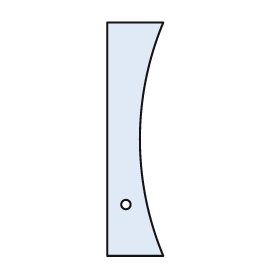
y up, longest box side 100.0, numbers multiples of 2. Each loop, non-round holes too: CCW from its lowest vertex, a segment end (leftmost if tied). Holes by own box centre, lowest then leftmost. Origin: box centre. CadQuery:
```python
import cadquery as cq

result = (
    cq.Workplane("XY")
    .moveTo(-12.0, -50.0)
    .lineTo(12.0, -50.0)
    .threePointArc((2.0, 0.0), (12.0, 50.0))
    .lineTo(-12.0, 50.0)
    .close()
    .moveTo(-4.0, -28.0)
    .circle(2.0)
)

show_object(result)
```